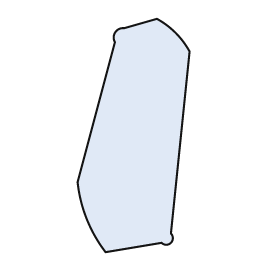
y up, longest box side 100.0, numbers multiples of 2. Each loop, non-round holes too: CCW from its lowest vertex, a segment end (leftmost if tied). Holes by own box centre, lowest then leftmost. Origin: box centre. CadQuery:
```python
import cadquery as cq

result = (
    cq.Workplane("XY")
    .moveTo(-12.0, -50.0)
    .lineTo(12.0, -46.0)
    .threePointArc((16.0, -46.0), (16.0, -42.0))
    .lineTo(24.0, 36.0)
    .threePointArc((18.0, 44.0), (10.0, 50.0))
    .lineTo(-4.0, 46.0)
    .threePointArc((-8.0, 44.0), (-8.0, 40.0))
    .lineTo(-24.0, -20.0)
    .threePointArc((-20.0, -36.0), (-12.0, -50.0))
    .close()
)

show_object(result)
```